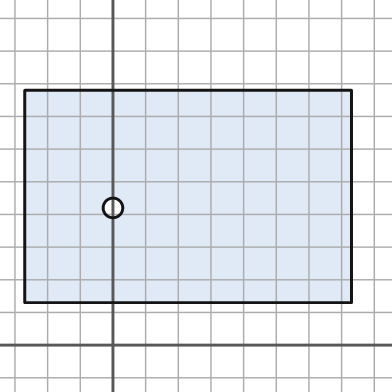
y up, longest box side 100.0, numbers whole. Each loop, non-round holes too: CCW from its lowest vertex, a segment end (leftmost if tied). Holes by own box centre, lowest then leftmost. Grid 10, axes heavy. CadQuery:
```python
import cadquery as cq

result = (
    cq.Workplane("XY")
    .moveTo(-27.0, 13.0)
    .lineTo(73.0, 13.0)
    .lineTo(73.0, 78.0)
    .lineTo(-27.0, 78.0)
    .close()
    .moveTo(0.0, 42.0)
    .circle(3.0)
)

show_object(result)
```